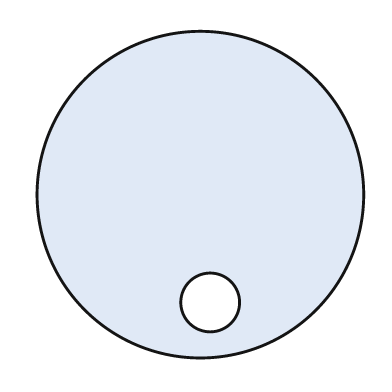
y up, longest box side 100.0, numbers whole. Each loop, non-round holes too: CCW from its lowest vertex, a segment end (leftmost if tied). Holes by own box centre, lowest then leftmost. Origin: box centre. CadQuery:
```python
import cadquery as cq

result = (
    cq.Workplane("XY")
    .moveTo(0.0, 0.0)
    .circle(50.0)
    .moveTo(3.0, -33.0)
    .circle(9.0)
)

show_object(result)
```